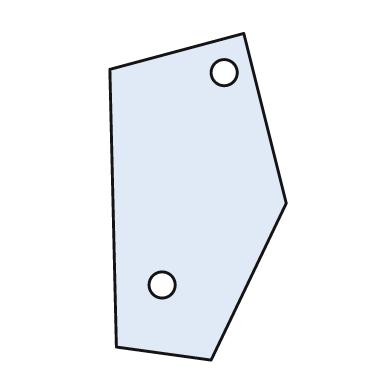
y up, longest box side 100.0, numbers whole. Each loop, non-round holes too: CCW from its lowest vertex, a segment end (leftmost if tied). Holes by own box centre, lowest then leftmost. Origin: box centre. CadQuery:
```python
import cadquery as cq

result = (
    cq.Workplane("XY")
    .moveTo(4.0, -50.0)
    .lineTo(27.0, -2.0)
    .lineTo(14.0, 50.0)
    .lineTo(-27.0, 39.0)
    .lineTo(-25.0, -46.0)
    .close()
    .moveTo(-11.0, -27.0)
    .circle(4.0)
    .moveTo(8.0, 38.0)
    .circle(4.0)
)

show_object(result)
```